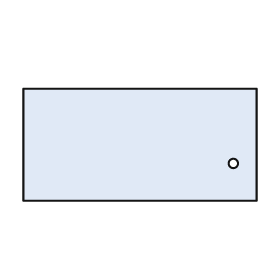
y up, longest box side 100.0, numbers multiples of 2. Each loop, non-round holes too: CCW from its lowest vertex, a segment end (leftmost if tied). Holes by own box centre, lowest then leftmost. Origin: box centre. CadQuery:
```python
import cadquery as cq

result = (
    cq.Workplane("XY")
    .moveTo(-50.0, -24.0)
    .lineTo(50.0, -24.0)
    .lineTo(50.0, 24.0)
    .lineTo(-50.0, 24.0)
    .close()
    .moveTo(40.0, -8.0)
    .circle(2.0)
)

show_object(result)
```